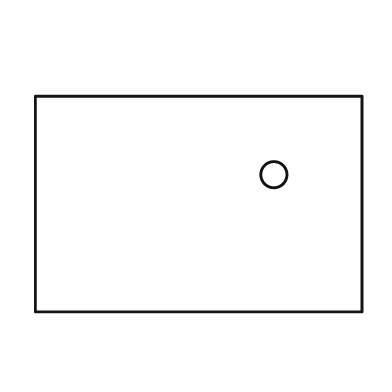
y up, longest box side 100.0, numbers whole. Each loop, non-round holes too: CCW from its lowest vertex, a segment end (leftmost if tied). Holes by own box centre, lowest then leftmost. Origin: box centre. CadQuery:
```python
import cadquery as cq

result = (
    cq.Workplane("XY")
    .moveTo(-50.0, -33.0)
    .lineTo(50.0, -33.0)
    .lineTo(50.0, 33.0)
    .lineTo(-50.0, 33.0)
    .close()
    .moveTo(23.0, 9.0)
    .circle(4.0)
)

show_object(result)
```